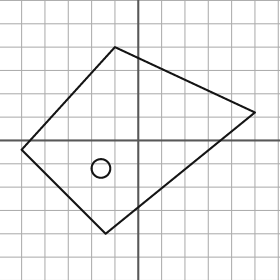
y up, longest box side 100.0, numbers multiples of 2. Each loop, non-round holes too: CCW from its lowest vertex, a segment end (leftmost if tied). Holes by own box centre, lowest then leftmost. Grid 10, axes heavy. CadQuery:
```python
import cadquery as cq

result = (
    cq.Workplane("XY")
    .moveTo(-14.0, -40.0)
    .lineTo(50.0, 12.0)
    .lineTo(-10.0, 40.0)
    .lineTo(-50.0, -4.0)
    .close()
    .moveTo(-16.0, -12.0)
    .circle(4.0)
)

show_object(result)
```